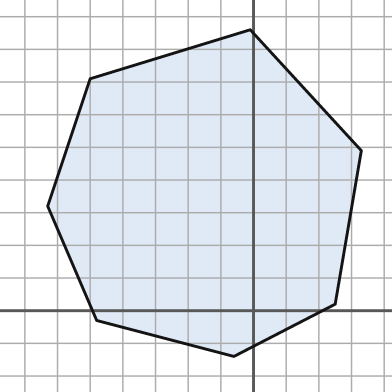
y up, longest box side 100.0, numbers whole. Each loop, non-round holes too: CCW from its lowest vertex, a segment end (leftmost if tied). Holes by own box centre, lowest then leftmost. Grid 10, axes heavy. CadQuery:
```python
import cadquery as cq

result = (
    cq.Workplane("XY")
    .moveTo(-6.0, -14.0)
    .lineTo(25.0, 2.0)
    .lineTo(33.0, 49.0)
    .lineTo(-1.0, 86.0)
    .lineTo(-50.0, 71.0)
    .lineTo(-63.0, 32.0)
    .lineTo(-48.0, -3.0)
    .close()
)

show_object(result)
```